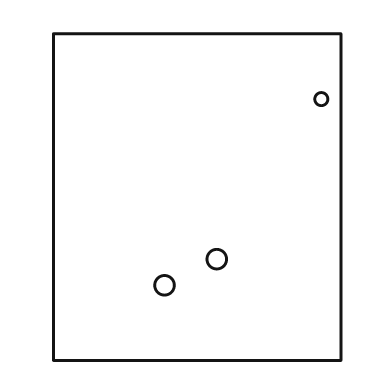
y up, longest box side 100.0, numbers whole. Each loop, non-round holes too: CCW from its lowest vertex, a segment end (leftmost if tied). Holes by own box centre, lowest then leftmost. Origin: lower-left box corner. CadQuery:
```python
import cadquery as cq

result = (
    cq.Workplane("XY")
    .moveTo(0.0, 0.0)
    .lineTo(88.0, 0.0)
    .lineTo(88.0, 100.0)
    .lineTo(0.0, 100.0)
    .close()
    .moveTo(34.0, 23.0)
    .circle(3.0)
    .moveTo(50.0, 31.0)
    .circle(3.0)
    .moveTo(82.0, 80.0)
    .circle(2.0)
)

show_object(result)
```